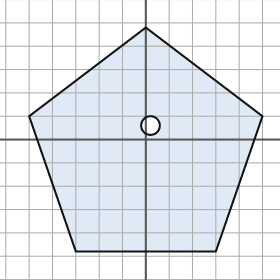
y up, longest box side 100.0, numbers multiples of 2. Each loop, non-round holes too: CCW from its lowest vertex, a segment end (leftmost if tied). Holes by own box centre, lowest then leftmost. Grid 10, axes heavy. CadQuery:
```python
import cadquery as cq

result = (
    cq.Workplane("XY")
    .moveTo(-30.0, -48.0)
    .lineTo(30.0, -48.0)
    .lineTo(50.0, 10.0)
    .lineTo(0.0, 48.0)
    .lineTo(-50.0, 10.0)
    .close()
    .moveTo(2.0, 6.0)
    .circle(4.0)
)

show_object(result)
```